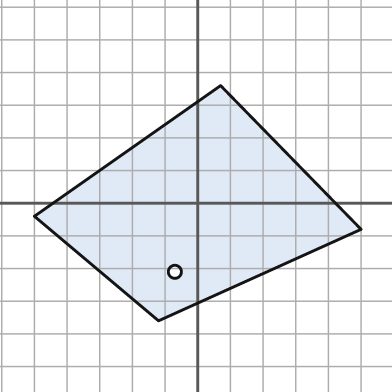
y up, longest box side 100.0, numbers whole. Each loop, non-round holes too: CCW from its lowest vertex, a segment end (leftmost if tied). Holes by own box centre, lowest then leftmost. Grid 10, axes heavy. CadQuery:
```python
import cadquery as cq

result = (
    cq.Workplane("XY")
    .moveTo(-12.0, -36.0)
    .lineTo(50.0, -8.0)
    .lineTo(7.0, 36.0)
    .lineTo(-50.0, -4.0)
    .close()
    .moveTo(-7.0, -21.0)
    .circle(2.0)
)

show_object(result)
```